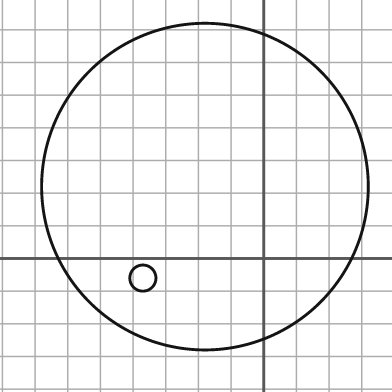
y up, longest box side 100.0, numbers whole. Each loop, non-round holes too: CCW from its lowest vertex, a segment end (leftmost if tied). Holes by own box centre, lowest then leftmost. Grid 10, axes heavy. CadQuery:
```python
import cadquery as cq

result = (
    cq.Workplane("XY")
    .moveTo(-18.0, 22.0)
    .circle(50.0)
    .moveTo(-37.0, -6.0)
    .circle(4.0)
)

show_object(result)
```